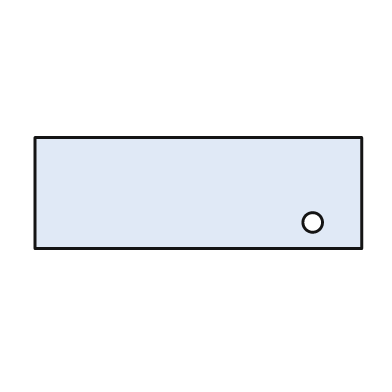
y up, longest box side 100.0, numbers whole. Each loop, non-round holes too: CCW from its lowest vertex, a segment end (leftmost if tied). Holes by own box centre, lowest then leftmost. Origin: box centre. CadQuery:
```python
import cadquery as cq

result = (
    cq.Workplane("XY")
    .moveTo(-50.0, -17.0)
    .lineTo(50.0, -17.0)
    .lineTo(50.0, 17.0)
    .lineTo(-50.0, 17.0)
    .close()
    .moveTo(35.0, -9.0)
    .circle(3.0)
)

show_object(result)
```